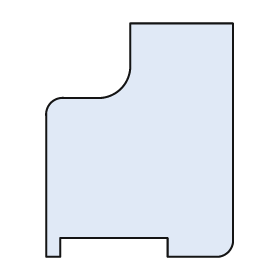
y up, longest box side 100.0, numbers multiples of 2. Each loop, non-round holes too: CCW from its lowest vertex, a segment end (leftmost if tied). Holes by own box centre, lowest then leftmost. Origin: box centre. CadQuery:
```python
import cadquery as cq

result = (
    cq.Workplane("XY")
    .moveTo(-40.0, -50.0)
    .lineTo(-34.0, -50.0)
    .lineTo(-34.0, -42.0)
    .lineTo(12.0, -42.0)
    .lineTo(12.0, -50.0)
    .lineTo(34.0, -50.0)
    .threePointArc((38.0, -48.0), (40.0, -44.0))
    .lineTo(40.0, 50.0)
    .lineTo(-4.0, 50.0)
    .lineTo(-4.0, 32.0)
    .threePointArc((-8.0, 22.0), (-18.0, 18.0))
    .lineTo(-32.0, 18.0)
    .threePointArc((-38.0, 16.0), (-40.0, 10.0))
    .close()
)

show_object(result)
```